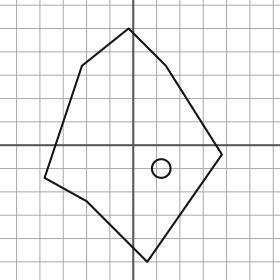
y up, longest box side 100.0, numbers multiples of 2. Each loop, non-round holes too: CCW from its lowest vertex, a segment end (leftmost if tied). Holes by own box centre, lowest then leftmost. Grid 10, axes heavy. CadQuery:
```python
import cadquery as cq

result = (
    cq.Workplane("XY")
    .moveTo(6.0, -50.0)
    .lineTo(38.0, -4.0)
    .lineTo(14.0, 34.0)
    .lineTo(-2.0, 50.0)
    .lineTo(-22.0, 34.0)
    .lineTo(-38.0, -14.0)
    .lineTo(-20.0, -24.0)
    .close()
    .moveTo(12.0, -10.0)
    .circle(4.0)
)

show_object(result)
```